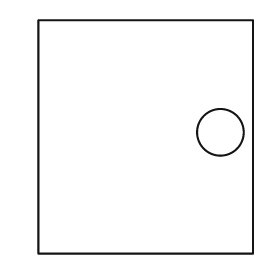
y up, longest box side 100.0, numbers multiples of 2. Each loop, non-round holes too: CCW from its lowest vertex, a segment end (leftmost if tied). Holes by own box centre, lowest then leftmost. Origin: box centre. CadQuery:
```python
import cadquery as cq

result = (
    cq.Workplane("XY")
    .moveTo(-46.0, -50.0)
    .lineTo(46.0, -50.0)
    .lineTo(46.0, 50.0)
    .lineTo(-46.0, 50.0)
    .close()
    .moveTo(32.0, 2.0)
    .circle(10.0)
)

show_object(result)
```